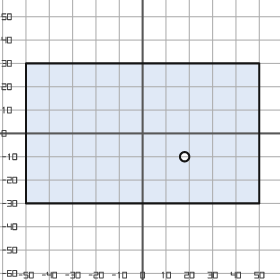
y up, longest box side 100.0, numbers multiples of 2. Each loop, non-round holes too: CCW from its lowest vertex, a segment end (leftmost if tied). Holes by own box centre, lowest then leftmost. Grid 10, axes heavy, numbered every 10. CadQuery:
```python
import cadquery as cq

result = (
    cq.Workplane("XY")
    .moveTo(-50.0, -30.0)
    .lineTo(50.0, -30.0)
    .lineTo(50.0, 30.0)
    .lineTo(-50.0, 30.0)
    .close()
    .moveTo(18.0, -10.0)
    .circle(2.0)
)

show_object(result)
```